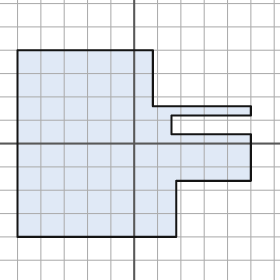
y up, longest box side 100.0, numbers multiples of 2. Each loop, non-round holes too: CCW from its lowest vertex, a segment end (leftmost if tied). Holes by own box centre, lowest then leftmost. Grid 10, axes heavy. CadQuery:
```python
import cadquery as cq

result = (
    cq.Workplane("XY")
    .moveTo(-50.0, -40.0)
    .lineTo(18.0, -40.0)
    .lineTo(18.0, -16.0)
    .lineTo(50.0, -16.0)
    .lineTo(50.0, 4.0)
    .lineTo(16.0, 4.0)
    .lineTo(16.0, 12.0)
    .lineTo(50.0, 12.0)
    .lineTo(50.0, 16.0)
    .lineTo(8.0, 16.0)
    .lineTo(8.0, 40.0)
    .lineTo(-50.0, 40.0)
    .close()
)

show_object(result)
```